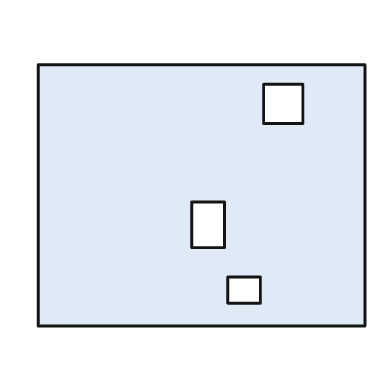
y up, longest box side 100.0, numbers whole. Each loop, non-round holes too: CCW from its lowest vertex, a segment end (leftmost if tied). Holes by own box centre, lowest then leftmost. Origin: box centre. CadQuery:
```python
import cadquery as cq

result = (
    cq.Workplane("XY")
    .moveTo(-50.0, -40.0)
    .lineTo(50.0, -40.0)
    .lineTo(50.0, 40.0)
    .lineTo(-50.0, 40.0)
    .close()
    .moveTo(8.0, -33.0)
    .lineTo(18.0, -33.0)
    .lineTo(18.0, -25.0)
    .lineTo(8.0, -25.0)
    .close()
    .moveTo(-3.0, -16.0)
    .lineTo(7.0, -16.0)
    .lineTo(7.0, -2.0)
    .lineTo(-3.0, -2.0)
    .close()
    .moveTo(19.0, 22.0)
    .lineTo(31.0, 22.0)
    .lineTo(31.0, 34.0)
    .lineTo(19.0, 34.0)
    .close()
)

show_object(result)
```